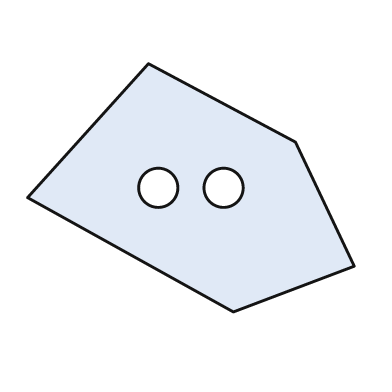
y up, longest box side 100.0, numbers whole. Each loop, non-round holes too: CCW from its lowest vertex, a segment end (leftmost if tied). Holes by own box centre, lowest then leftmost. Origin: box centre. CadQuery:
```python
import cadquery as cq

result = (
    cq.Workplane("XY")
    .moveTo(13.0, -38.0)
    .lineTo(50.0, -24.0)
    .lineTo(32.0, 14.0)
    .lineTo(-13.0, 38.0)
    .lineTo(-50.0, -3.0)
    .close()
    .moveTo(-10.0, 0.0)
    .circle(6.0)
    .moveTo(10.0, 0.0)
    .circle(6.0)
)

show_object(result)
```